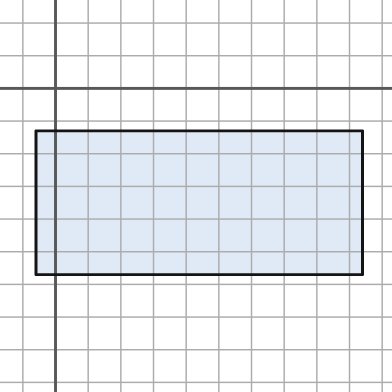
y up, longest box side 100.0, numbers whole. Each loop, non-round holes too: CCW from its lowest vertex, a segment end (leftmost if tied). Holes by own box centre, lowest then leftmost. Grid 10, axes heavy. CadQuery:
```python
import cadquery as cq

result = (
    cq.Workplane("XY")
    .moveTo(-6.0, -57.0)
    .lineTo(94.0, -57.0)
    .lineTo(94.0, -13.0)
    .lineTo(-6.0, -13.0)
    .close()
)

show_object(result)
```